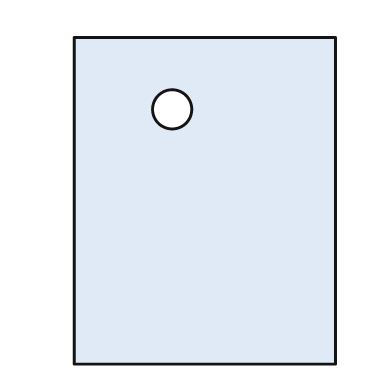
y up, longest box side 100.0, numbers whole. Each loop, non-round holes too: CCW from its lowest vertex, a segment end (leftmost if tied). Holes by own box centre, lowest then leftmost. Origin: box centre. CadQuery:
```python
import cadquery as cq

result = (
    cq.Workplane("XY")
    .moveTo(-40.0, -50.0)
    .lineTo(40.0, -50.0)
    .lineTo(40.0, 50.0)
    .lineTo(-40.0, 50.0)
    .close()
    .moveTo(-10.0, 28.0)
    .circle(6.0)
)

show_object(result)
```